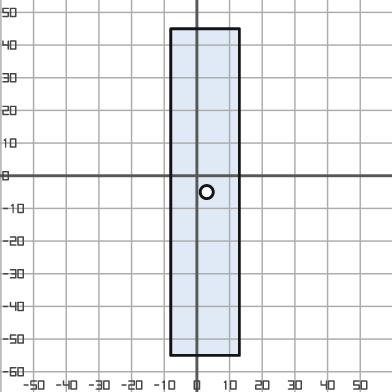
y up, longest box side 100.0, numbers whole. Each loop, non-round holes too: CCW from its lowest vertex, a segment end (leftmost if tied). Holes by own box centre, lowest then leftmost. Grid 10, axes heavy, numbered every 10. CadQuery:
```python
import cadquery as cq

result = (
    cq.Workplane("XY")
    .moveTo(-8.0, -55.0)
    .lineTo(13.0, -55.0)
    .lineTo(13.0, 45.0)
    .lineTo(-8.0, 45.0)
    .close()
    .moveTo(3.0, -5.0)
    .circle(2.0)
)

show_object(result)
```